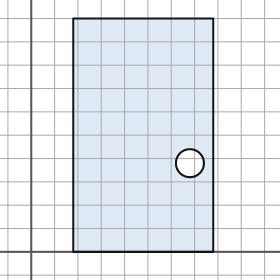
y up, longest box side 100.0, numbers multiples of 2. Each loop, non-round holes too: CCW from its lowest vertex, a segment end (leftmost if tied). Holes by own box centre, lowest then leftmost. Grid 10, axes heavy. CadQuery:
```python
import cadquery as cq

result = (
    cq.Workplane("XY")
    .moveTo(18.0, 0.0)
    .lineTo(78.0, 0.0)
    .lineTo(78.0, 100.0)
    .lineTo(18.0, 100.0)
    .close()
    .moveTo(68.0, 38.0)
    .circle(6.0)
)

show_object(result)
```